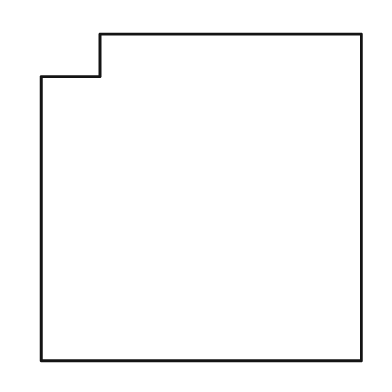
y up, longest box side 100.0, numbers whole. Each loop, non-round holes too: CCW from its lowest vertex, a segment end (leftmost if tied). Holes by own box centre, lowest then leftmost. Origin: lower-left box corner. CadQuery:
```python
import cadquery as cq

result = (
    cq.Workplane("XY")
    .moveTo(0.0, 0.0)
    .lineTo(98.0, 0.0)
    .lineTo(98.0, 100.0)
    .lineTo(18.0, 100.0)
    .lineTo(18.0, 87.0)
    .lineTo(0.0, 87.0)
    .close()
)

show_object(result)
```